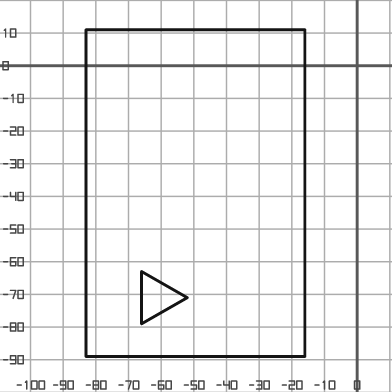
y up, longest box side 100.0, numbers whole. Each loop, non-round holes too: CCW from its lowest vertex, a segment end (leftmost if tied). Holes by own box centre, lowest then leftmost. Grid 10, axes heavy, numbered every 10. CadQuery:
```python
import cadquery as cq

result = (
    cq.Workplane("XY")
    .moveTo(-83.0, -89.0)
    .lineTo(-16.0, -89.0)
    .lineTo(-16.0, 11.0)
    .lineTo(-83.0, 11.0)
    .close()
    .moveTo(-66.0, -79.0)
    .lineTo(-52.0, -71.0)
    .lineTo(-66.0, -63.0)
    .close()
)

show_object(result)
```